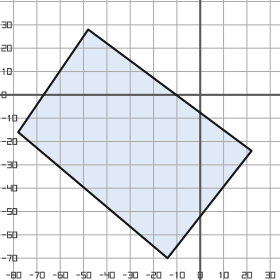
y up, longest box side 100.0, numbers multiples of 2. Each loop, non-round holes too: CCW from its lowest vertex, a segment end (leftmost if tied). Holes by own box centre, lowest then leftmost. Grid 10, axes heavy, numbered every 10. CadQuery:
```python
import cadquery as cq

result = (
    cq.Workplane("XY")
    .moveTo(-14.0, -70.0)
    .lineTo(22.0, -24.0)
    .lineTo(-48.0, 28.0)
    .lineTo(-78.0, -16.0)
    .close()
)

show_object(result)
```